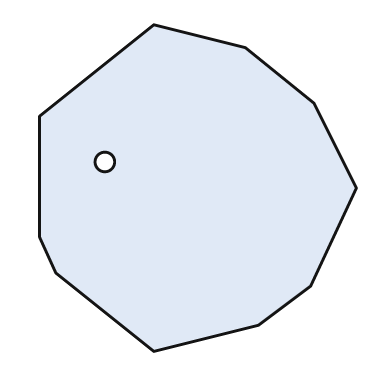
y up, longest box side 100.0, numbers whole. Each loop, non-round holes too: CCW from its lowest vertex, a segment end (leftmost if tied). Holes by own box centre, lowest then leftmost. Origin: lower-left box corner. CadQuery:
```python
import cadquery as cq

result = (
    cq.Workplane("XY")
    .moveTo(35.0, 0.0)
    .lineTo(67.0, 8.0)
    .lineTo(83.0, 20.0)
    .lineTo(97.0, 50.0)
    .lineTo(84.0, 76.0)
    .lineTo(63.0, 93.0)
    .lineTo(35.0, 100.0)
    .lineTo(0.0, 72.0)
    .lineTo(0.0, 35.0)
    .lineTo(5.0, 24.0)
    .close()
    .moveTo(20.0, 58.0)
    .circle(3.0)
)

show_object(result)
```